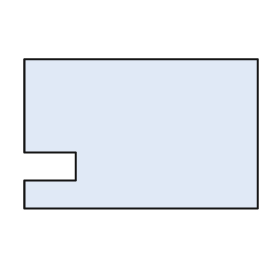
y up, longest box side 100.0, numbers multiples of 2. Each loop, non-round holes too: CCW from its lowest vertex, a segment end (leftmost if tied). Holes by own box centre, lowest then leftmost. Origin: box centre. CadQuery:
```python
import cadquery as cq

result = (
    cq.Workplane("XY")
    .moveTo(-50.0, -32.0)
    .lineTo(50.0, -32.0)
    .lineTo(50.0, 32.0)
    .lineTo(-50.0, 32.0)
    .lineTo(-50.0, -8.0)
    .lineTo(-28.0, -8.0)
    .lineTo(-28.0, -20.0)
    .lineTo(-50.0, -20.0)
    .close()
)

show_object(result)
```